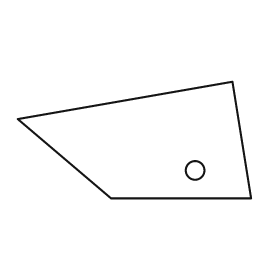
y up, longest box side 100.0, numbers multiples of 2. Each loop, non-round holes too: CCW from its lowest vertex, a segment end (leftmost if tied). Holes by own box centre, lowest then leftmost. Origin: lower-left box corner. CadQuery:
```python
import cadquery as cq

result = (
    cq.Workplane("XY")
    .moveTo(40.0, 0.0)
    .lineTo(100.0, 0.0)
    .lineTo(92.0, 50.0)
    .lineTo(0.0, 34.0)
    .close()
    .moveTo(76.0, 12.0)
    .circle(4.0)
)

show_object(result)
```